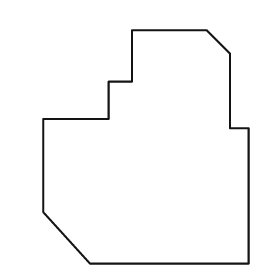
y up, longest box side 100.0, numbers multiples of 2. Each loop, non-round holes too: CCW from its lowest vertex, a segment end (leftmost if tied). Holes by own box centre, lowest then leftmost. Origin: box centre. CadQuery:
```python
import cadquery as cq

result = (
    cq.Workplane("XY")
    .moveTo(-24.0, -50.0)
    .lineTo(44.0, -50.0)
    .lineTo(44.0, 8.0)
    .lineTo(36.0, 8.0)
    .lineTo(36.0, 40.0)
    .lineTo(26.0, 50.0)
    .lineTo(-6.0, 50.0)
    .lineTo(-6.0, 28.0)
    .lineTo(-16.0, 28.0)
    .lineTo(-16.0, 12.0)
    .lineTo(-44.0, 12.0)
    .lineTo(-44.0, -28.0)
    .close()
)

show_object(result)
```